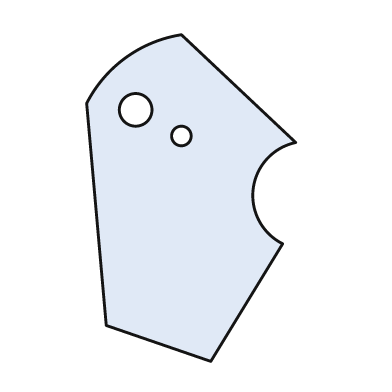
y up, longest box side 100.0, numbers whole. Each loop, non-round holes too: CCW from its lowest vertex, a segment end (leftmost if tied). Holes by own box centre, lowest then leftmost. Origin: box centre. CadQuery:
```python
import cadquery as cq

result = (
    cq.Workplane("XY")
    .moveTo(6.0, -50.0)
    .lineTo(28.0, -14.0)
    .threePointArc((19.0, 3.0), (32.0, 17.0))
    .lineTo(-3.0, 50.0)
    .threePointArc((-20.0, 43.0), (-32.0, 29.0))
    .lineTo(-26.0, -39.0)
    .close()
    .moveTo(-3.0, 19.0)
    .circle(3.0)
    .moveTo(-17.0, 27.0)
    .circle(5.0)
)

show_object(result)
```